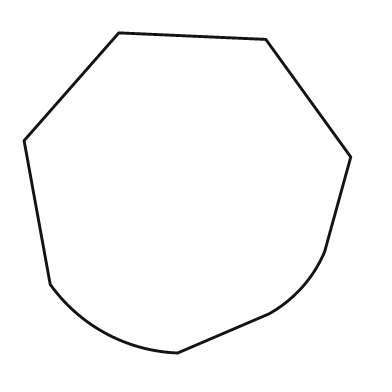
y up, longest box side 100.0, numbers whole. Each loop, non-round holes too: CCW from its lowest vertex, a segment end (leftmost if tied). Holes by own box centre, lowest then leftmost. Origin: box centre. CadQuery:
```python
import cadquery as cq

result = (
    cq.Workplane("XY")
    .moveTo(-3.0, -49.0)
    .lineTo(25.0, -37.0)
    .threePointArc((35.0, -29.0), (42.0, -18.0))
    .lineTo(50.0, 11.0)
    .lineTo(24.0, 47.0)
    .lineTo(-21.0, 49.0)
    .lineTo(-50.0, 16.0)
    .lineTo(-42.0, -28.0)
    .threePointArc((-25.0, -43.0), (-3.0, -49.0))
    .close()
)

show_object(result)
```